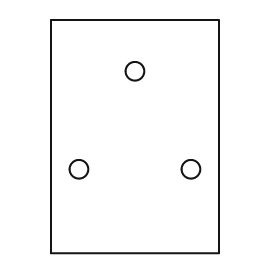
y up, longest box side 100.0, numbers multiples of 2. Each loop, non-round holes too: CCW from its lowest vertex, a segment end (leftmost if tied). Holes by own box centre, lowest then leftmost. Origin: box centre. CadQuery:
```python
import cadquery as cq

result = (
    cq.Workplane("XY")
    .moveTo(-36.0, -50.0)
    .lineTo(36.0, -50.0)
    .lineTo(36.0, 50.0)
    .lineTo(-36.0, 50.0)
    .close()
    .moveTo(-24.0, -14.0)
    .circle(4.0)
    .moveTo(24.0, -14.0)
    .circle(4.0)
    .moveTo(0.0, 28.0)
    .circle(4.0)
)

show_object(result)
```